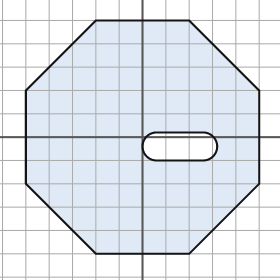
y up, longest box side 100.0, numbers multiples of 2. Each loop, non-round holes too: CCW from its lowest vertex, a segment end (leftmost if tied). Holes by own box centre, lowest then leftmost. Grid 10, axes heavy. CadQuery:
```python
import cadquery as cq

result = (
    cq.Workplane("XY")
    .moveTo(-20.0, -50.0)
    .lineTo(20.0, -50.0)
    .lineTo(50.0, -20.0)
    .lineTo(50.0, 20.0)
    .lineTo(20.0, 50.0)
    .lineTo(-20.0, 50.0)
    .lineTo(-50.0, 20.0)
    .lineTo(-50.0, -20.0)
    .close()
    .moveTo(6.0, -10.0)
    .lineTo(26.0, -10.0)
    .threePointArc((32.0, -4.0), (26.0, 2.0))
    .lineTo(6.0, 2.0)
    .threePointArc((0.0, -4.0), (6.0, -10.0))
    .close()
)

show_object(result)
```